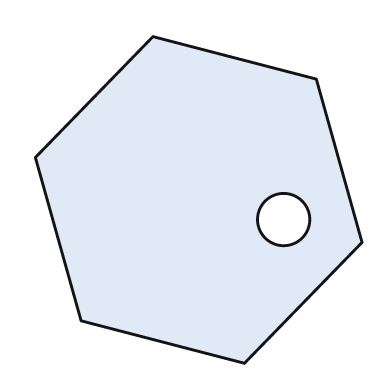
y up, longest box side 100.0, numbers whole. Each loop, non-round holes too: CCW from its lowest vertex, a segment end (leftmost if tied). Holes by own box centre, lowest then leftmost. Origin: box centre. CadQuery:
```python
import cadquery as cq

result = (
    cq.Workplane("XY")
    .moveTo(14.0, -50.0)
    .lineTo(50.0, -13.0)
    .lineTo(36.0, 37.0)
    .lineTo(-14.0, 50.0)
    .lineTo(-50.0, 13.0)
    .lineTo(-36.0, -37.0)
    .close()
    .moveTo(26.0, -6.0)
    .circle(8.0)
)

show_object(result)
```